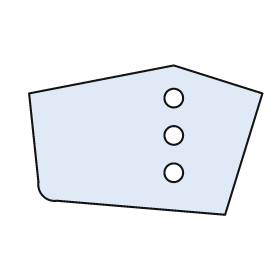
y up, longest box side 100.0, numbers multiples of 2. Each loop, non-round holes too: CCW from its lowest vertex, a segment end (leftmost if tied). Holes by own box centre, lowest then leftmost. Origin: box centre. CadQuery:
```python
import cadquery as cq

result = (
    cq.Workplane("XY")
    .moveTo(34.0, -32.0)
    .lineTo(50.0, 20.0)
    .lineTo(12.0, 32.0)
    .lineTo(-50.0, 20.0)
    .lineTo(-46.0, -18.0)
    .threePointArc((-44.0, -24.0), (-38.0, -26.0))
    .close()
    .moveTo(12.0, -14.0)
    .circle(4.0)
    .moveTo(12.0, 2.0)
    .circle(4.0)
    .moveTo(12.0, 18.0)
    .circle(4.0)
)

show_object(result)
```